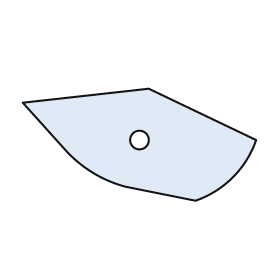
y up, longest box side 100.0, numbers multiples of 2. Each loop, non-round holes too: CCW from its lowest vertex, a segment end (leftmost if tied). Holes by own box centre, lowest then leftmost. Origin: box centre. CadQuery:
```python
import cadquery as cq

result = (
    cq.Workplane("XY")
    .moveTo(24.0, -24.0)
    .threePointArc((40.0, -14.0), (50.0, 2.0))
    .lineTo(4.0, 24.0)
    .lineTo(-50.0, 18.0)
    .lineTo(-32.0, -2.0)
    .threePointArc((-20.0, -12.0), (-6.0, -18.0))
    .close()
    .moveTo(0.0, 2.0)
    .circle(4.0)
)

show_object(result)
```